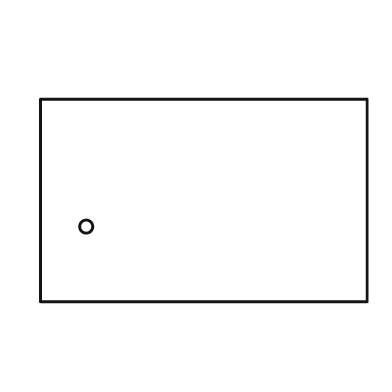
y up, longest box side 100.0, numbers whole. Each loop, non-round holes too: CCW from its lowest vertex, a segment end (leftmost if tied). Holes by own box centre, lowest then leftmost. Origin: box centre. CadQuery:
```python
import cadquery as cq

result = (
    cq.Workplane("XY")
    .moveTo(-50.0, -31.0)
    .lineTo(50.0, -31.0)
    .lineTo(50.0, 31.0)
    .lineTo(-50.0, 31.0)
    .close()
    .moveTo(-36.0, -8.0)
    .circle(2.0)
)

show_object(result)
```